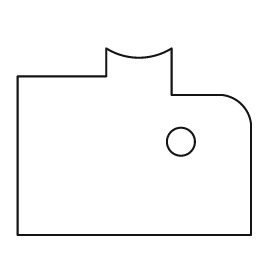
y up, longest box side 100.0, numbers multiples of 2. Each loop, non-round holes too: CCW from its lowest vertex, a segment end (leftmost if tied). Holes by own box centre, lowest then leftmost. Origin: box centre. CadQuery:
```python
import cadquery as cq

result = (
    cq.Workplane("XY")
    .moveTo(-50.0, -40.0)
    .lineTo(50.0, -40.0)
    .lineTo(50.0, 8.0)
    .threePointArc((46.0, 16.0), (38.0, 20.0))
    .lineTo(16.0, 20.0)
    .lineTo(16.0, 40.0)
    .threePointArc((2.0, 36.0), (-12.0, 40.0))
    .lineTo(-12.0, 28.0)
    .lineTo(-50.0, 28.0)
    .close()
    .moveTo(20.0, 0.0)
    .circle(6.0)
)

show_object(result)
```